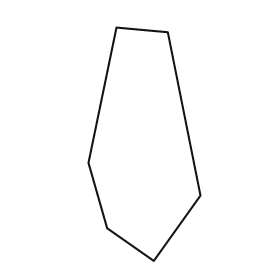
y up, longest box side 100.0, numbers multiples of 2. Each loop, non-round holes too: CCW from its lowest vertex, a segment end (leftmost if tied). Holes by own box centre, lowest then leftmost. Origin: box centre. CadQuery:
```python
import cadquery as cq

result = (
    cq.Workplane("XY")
    .moveTo(4.0, -50.0)
    .lineTo(24.0, -22.0)
    .lineTo(10.0, 48.0)
    .lineTo(-12.0, 50.0)
    .lineTo(-24.0, -8.0)
    .lineTo(-16.0, -36.0)
    .close()
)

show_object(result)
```